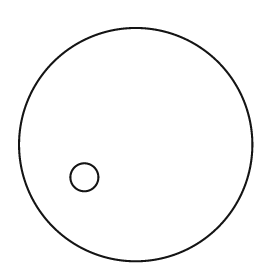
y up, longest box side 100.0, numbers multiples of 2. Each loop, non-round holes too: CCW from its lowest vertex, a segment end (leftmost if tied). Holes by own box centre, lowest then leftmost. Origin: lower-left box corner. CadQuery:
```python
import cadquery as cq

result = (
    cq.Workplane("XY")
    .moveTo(50.0, 50.0)
    .circle(50.0)
    .moveTo(28.0, 36.0)
    .circle(6.0)
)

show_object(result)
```